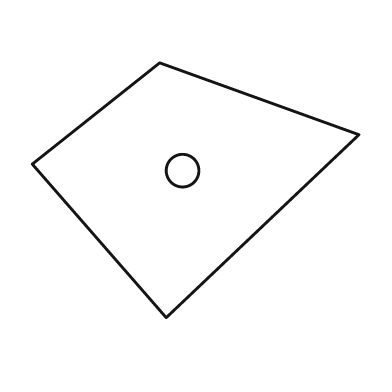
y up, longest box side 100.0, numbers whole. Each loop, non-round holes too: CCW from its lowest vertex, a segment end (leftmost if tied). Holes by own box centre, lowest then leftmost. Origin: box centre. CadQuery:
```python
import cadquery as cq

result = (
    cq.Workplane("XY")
    .moveTo(-9.0, -39.0)
    .lineTo(50.0, 17.0)
    .lineTo(-11.0, 39.0)
    .lineTo(-50.0, 8.0)
    .close()
    .moveTo(-4.0, 6.0)
    .circle(5.0)
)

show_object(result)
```